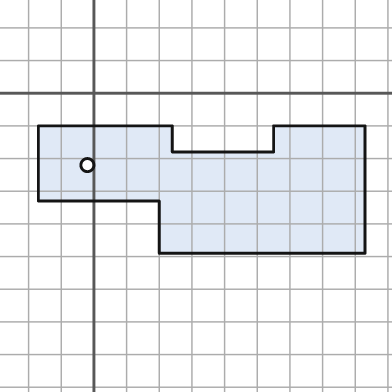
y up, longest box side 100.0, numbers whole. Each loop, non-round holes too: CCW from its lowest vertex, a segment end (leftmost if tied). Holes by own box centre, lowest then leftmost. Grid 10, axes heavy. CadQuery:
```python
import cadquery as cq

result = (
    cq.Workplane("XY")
    .moveTo(20.0, -49.0)
    .lineTo(83.0, -49.0)
    .lineTo(83.0, -10.0)
    .lineTo(55.0, -10.0)
    .lineTo(55.0, -18.0)
    .lineTo(24.0, -18.0)
    .lineTo(24.0, -10.0)
    .lineTo(-17.0, -10.0)
    .lineTo(-17.0, -33.0)
    .lineTo(20.0, -33.0)
    .close()
    .moveTo(-2.0, -22.0)
    .circle(2.0)
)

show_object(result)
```